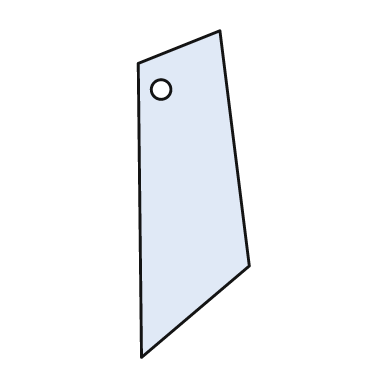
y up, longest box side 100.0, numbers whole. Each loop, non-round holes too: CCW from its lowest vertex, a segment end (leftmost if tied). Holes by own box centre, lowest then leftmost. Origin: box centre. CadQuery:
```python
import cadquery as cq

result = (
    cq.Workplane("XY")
    .moveTo(-16.0, -50.0)
    .lineTo(17.0, -22.0)
    .lineTo(8.0, 50.0)
    .lineTo(-17.0, 40.0)
    .close()
    .moveTo(-10.0, 32.0)
    .circle(3.0)
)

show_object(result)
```